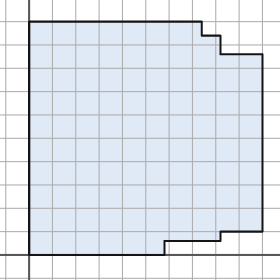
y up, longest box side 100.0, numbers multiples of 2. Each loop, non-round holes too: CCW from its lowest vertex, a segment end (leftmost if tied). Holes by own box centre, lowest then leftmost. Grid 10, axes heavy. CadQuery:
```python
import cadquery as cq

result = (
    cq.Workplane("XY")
    .moveTo(0.0, 0.0)
    .lineTo(58.0, 0.0)
    .lineTo(58.0, 6.0)
    .lineTo(82.0, 6.0)
    .lineTo(82.0, 10.0)
    .lineTo(100.0, 10.0)
    .lineTo(100.0, 86.0)
    .lineTo(82.0, 86.0)
    .lineTo(82.0, 94.0)
    .lineTo(74.0, 94.0)
    .lineTo(74.0, 100.0)
    .lineTo(0.0, 100.0)
    .close()
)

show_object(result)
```